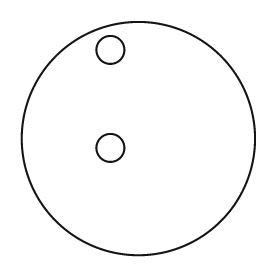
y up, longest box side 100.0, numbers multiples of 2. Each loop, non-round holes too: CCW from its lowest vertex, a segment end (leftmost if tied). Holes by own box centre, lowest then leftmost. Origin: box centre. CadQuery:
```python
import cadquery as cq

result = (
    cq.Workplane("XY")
    .moveTo(0.0, 0.0)
    .circle(50.0)
    .moveTo(-12.0, -4.0)
    .circle(6.0)
    .moveTo(-12.0, 38.0)
    .circle(6.0)
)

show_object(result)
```